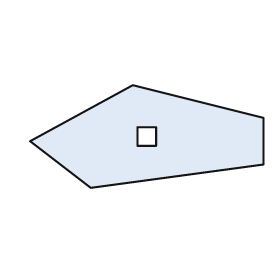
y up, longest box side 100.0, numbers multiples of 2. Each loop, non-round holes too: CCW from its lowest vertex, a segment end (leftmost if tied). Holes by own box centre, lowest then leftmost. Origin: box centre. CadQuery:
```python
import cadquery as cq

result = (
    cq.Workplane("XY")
    .moveTo(-24.0, -22.0)
    .lineTo(50.0, -12.0)
    .lineTo(50.0, 8.0)
    .lineTo(-6.0, 22.0)
    .lineTo(-50.0, -2.0)
    .close()
    .moveTo(-4.0, -4.0)
    .lineTo(4.0, -4.0)
    .lineTo(4.0, 4.0)
    .lineTo(-4.0, 4.0)
    .close()
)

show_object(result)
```